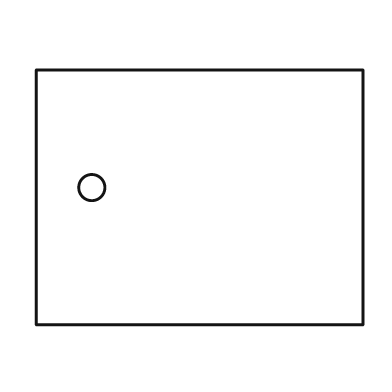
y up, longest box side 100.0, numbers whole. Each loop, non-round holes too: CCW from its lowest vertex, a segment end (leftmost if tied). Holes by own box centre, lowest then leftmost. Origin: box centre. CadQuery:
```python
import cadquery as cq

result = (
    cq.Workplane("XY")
    .moveTo(-50.0, -39.0)
    .lineTo(50.0, -39.0)
    .lineTo(50.0, 39.0)
    .lineTo(-50.0, 39.0)
    .close()
    .moveTo(-33.0, 3.0)
    .circle(4.0)
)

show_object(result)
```